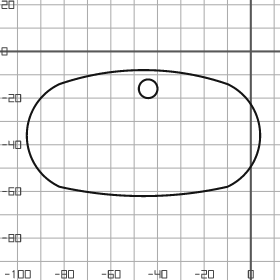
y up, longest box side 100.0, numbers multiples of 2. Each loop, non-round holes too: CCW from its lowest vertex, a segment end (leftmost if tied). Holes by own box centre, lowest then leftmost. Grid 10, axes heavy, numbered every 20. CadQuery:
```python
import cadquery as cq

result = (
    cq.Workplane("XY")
    .moveTo(-82.0, -58.0)
    .threePointArc((-46.0, -62.0), (-10.0, -58.0))
    .threePointArc((4.0, -36.0), (-10.0, -14.0))
    .threePointArc((-46.0, -8.0), (-82.0, -14.0))
    .threePointArc((-96.0, -36.0), (-82.0, -58.0))
    .close()
    .moveTo(-44.0, -16.0)
    .circle(4.0)
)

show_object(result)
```